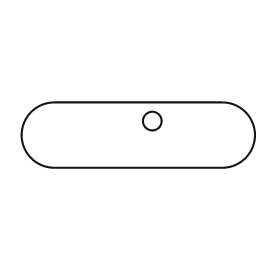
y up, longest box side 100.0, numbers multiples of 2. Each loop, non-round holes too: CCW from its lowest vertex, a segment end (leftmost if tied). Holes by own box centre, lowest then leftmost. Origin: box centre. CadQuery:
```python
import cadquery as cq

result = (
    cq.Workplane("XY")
    .moveTo(-36.0, -14.0)
    .lineTo(36.0, -14.0)
    .threePointArc((50.0, 0.0), (36.0, 14.0))
    .lineTo(-36.0, 14.0)
    .threePointArc((-50.0, 0.0), (-36.0, -14.0))
    .close()
    .moveTo(6.0, 6.0)
    .circle(4.0)
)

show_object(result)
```